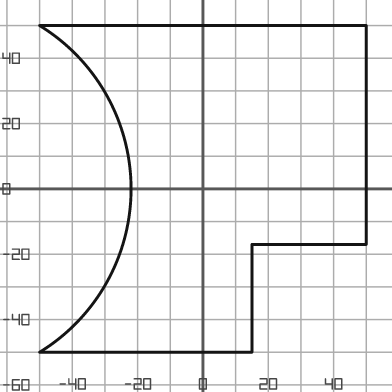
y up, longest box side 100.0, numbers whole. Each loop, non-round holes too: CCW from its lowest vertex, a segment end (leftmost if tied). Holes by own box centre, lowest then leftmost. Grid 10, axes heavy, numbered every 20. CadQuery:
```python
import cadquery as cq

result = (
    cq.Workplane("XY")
    .moveTo(-50.0, -50.0)
    .lineTo(15.0, -50.0)
    .lineTo(15.0, -17.0)
    .lineTo(50.0, -17.0)
    .lineTo(50.0, 50.0)
    .lineTo(-50.0, 50.0)
    .threePointArc((-22.0, 0.0), (-50.0, -50.0))
    .close()
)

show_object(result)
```